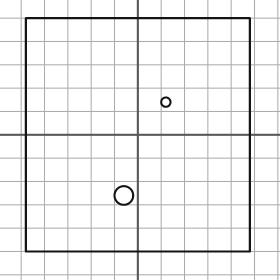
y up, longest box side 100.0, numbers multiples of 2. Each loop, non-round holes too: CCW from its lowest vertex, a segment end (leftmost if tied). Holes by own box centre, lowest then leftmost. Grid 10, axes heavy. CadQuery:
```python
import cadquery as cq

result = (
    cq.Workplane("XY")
    .moveTo(-48.0, -50.0)
    .lineTo(48.0, -50.0)
    .lineTo(48.0, 50.0)
    .lineTo(-48.0, 50.0)
    .close()
    .moveTo(-6.0, -26.0)
    .circle(4.0)
    .moveTo(12.0, 14.0)
    .circle(2.0)
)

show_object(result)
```